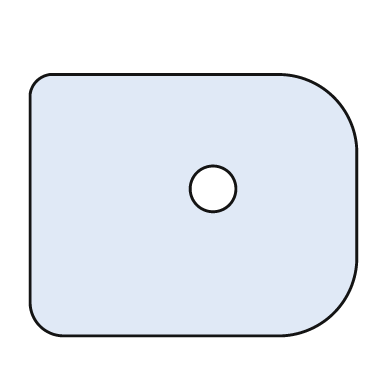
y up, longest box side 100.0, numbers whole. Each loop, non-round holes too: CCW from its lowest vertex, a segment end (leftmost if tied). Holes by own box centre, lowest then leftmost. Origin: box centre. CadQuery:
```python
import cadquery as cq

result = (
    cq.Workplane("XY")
    .moveTo(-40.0, -40.0)
    .lineTo(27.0, -40.0)
    .threePointArc((43.0, -33.0), (50.0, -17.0))
    .lineTo(50.0, 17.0)
    .threePointArc((43.0, 33.0), (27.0, 40.0))
    .lineTo(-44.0, 40.0)
    .threePointArc((-48.0, 38.0), (-50.0, 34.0))
    .lineTo(-50.0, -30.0)
    .threePointArc((-47.0, -37.0), (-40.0, -40.0))
    .close()
    .moveTo(6.0, 5.0)
    .circle(7.0)
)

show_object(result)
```